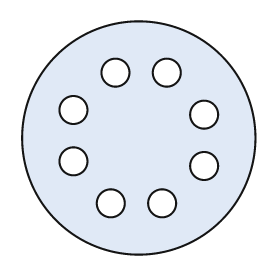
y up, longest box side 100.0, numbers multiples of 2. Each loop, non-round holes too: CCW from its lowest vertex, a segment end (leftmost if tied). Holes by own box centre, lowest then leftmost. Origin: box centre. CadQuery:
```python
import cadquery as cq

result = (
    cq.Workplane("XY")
    .moveTo(0.0, 0.0)
    .circle(50.0)
    .moveTo(-12.0, -28.0)
    .circle(6.0)
    .moveTo(10.0, -28.0)
    .circle(6.0)
    .moveTo(28.0, -12.0)
    .circle(6.0)
    .moveTo(-28.0, -10.0)
    .circle(6.0)
    .moveTo(28.0, 10.0)
    .circle(6.0)
    .moveTo(-28.0, 12.0)
    .circle(6.0)
    .moveTo(-10.0, 28.0)
    .circle(6.0)
    .moveTo(12.0, 28.0)
    .circle(6.0)
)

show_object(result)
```